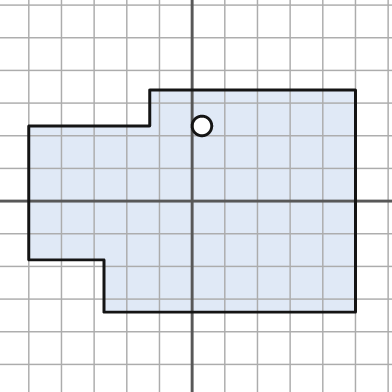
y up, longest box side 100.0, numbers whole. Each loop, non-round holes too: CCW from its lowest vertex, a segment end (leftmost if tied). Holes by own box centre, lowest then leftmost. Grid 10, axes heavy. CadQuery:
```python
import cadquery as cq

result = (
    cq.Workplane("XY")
    .moveTo(-27.0, -34.0)
    .lineTo(50.0, -34.0)
    .lineTo(50.0, 34.0)
    .lineTo(-13.0, 34.0)
    .lineTo(-13.0, 23.0)
    .lineTo(-50.0, 23.0)
    .lineTo(-50.0, -18.0)
    .lineTo(-27.0, -18.0)
    .close()
    .moveTo(3.0, 23.0)
    .circle(3.0)
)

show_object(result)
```